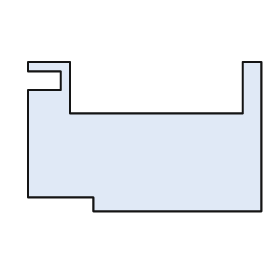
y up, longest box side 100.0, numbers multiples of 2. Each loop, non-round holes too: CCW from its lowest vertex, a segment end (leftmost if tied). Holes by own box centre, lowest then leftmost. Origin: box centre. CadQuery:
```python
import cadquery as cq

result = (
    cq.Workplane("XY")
    .moveTo(-22.0, -32.0)
    .lineTo(50.0, -32.0)
    .lineTo(50.0, 32.0)
    .lineTo(42.0, 32.0)
    .lineTo(42.0, 10.0)
    .lineTo(-32.0, 10.0)
    .lineTo(-32.0, 32.0)
    .lineTo(-50.0, 32.0)
    .lineTo(-50.0, 28.0)
    .lineTo(-36.0, 28.0)
    .lineTo(-36.0, 20.0)
    .lineTo(-50.0, 20.0)
    .lineTo(-50.0, -26.0)
    .lineTo(-22.0, -26.0)
    .close()
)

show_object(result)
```